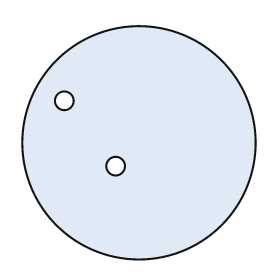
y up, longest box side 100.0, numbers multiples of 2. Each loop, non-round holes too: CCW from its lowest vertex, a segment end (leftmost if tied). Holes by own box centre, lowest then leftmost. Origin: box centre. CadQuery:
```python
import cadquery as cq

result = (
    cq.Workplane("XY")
    .moveTo(0.0, 0.0)
    .circle(50.0)
    .moveTo(-10.0, -10.0)
    .circle(4.0)
    .moveTo(-32.0, 18.0)
    .circle(4.0)
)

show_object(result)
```